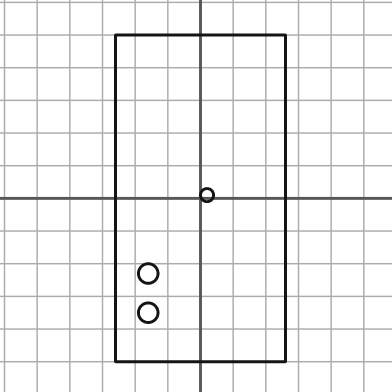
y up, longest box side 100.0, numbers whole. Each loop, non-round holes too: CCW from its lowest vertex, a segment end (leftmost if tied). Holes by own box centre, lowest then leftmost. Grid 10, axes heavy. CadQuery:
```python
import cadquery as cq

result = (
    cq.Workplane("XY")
    .moveTo(-26.0, -50.0)
    .lineTo(26.0, -50.0)
    .lineTo(26.0, 50.0)
    .lineTo(-26.0, 50.0)
    .close()
    .moveTo(-16.0, -35.0)
    .circle(3.0)
    .moveTo(-16.0, -23.0)
    .circle(3.0)
    .moveTo(2.0, 1.0)
    .circle(2.0)
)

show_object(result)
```